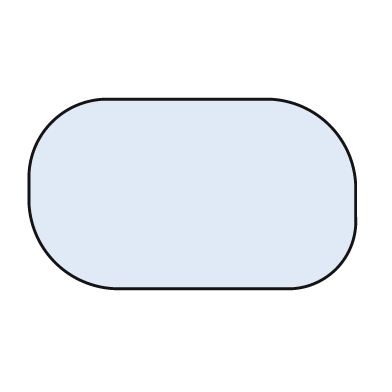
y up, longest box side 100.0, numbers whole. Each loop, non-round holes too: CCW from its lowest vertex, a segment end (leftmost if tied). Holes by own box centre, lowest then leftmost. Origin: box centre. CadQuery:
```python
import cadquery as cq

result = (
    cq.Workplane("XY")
    .moveTo(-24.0, -29.0)
    .lineTo(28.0, -29.0)
    .threePointArc((44.0, -23.0), (50.0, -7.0))
    .lineTo(50.0, 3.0)
    .threePointArc((42.0, 21.0), (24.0, 29.0))
    .lineTo(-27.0, 29.0)
    .threePointArc((-43.0, 22.0), (-50.0, 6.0))
    .lineTo(-50.0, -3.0)
    .threePointArc((-42.0, -21.0), (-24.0, -29.0))
    .close()
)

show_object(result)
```